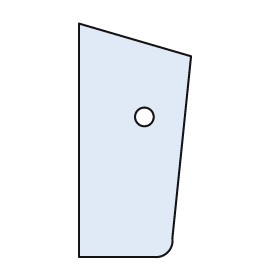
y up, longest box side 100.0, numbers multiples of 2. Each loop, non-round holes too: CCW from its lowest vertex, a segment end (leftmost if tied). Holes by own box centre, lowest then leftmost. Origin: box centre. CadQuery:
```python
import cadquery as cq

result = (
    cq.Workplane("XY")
    .moveTo(-24.0, -50.0)
    .lineTo(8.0, -50.0)
    .threePointArc((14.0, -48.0), (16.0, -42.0))
    .lineTo(24.0, 36.0)
    .lineTo(-24.0, 50.0)
    .close()
    .moveTo(4.0, 10.0)
    .circle(4.0)
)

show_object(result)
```